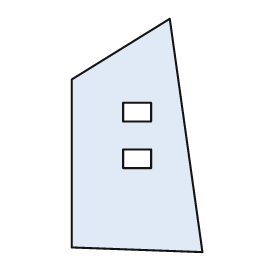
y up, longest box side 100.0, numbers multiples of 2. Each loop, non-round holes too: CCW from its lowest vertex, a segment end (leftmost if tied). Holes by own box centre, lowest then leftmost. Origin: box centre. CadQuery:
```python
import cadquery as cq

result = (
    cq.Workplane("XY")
    .moveTo(28.0, -50.0)
    .lineTo(14.0, 50.0)
    .lineTo(-28.0, 24.0)
    .lineTo(-28.0, -48.0)
    .close()
    .moveTo(-6.0, -14.0)
    .lineTo(6.0, -14.0)
    .lineTo(6.0, -6.0)
    .lineTo(-6.0, -6.0)
    .close()
    .moveTo(-6.0, 6.0)
    .lineTo(6.0, 6.0)
    .lineTo(6.0, 14.0)
    .lineTo(-6.0, 14.0)
    .close()
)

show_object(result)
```